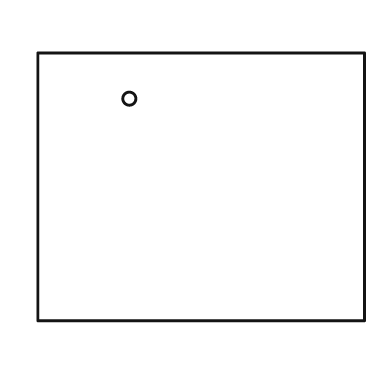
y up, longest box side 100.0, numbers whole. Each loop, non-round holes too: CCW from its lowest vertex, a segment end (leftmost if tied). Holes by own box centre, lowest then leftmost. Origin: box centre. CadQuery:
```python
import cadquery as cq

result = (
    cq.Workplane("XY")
    .moveTo(-50.0, -41.0)
    .lineTo(50.0, -41.0)
    .lineTo(50.0, 41.0)
    .lineTo(-50.0, 41.0)
    .close()
    .moveTo(-22.0, 27.0)
    .circle(2.0)
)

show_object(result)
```